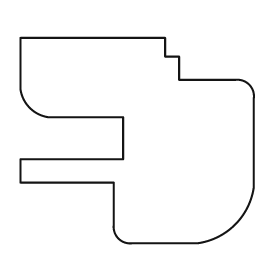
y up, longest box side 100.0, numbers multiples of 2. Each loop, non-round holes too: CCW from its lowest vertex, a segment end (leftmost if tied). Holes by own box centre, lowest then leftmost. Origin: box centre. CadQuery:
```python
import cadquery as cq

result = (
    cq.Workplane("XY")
    .moveTo(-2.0, -44.0)
    .lineTo(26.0, -44.0)
    .threePointArc((42.0, -36.0), (50.0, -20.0))
    .lineTo(50.0, 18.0)
    .threePointArc((48.0, 24.0), (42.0, 26.0))
    .lineTo(18.0, 26.0)
    .lineTo(18.0, 36.0)
    .lineTo(12.0, 36.0)
    .lineTo(12.0, 44.0)
    .lineTo(-50.0, 44.0)
    .lineTo(-50.0, 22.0)
    .threePointArc((-46.0, 14.0), (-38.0, 10.0))
    .lineTo(-6.0, 10.0)
    .lineTo(-6.0, -8.0)
    .lineTo(-50.0, -8.0)
    .lineTo(-50.0, -18.0)
    .lineTo(-10.0, -18.0)
    .lineTo(-10.0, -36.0)
    .threePointArc((-8.0, -42.0), (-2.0, -44.0))
    .close()
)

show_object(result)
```